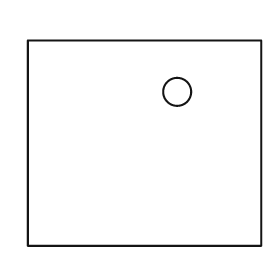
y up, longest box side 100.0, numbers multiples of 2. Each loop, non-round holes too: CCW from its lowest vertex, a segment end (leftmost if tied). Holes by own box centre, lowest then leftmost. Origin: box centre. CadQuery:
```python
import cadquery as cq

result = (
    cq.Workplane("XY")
    .moveTo(-50.0, -44.0)
    .lineTo(50.0, -44.0)
    .lineTo(50.0, 44.0)
    .lineTo(-50.0, 44.0)
    .close()
    .moveTo(14.0, 22.0)
    .circle(6.0)
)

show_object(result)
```